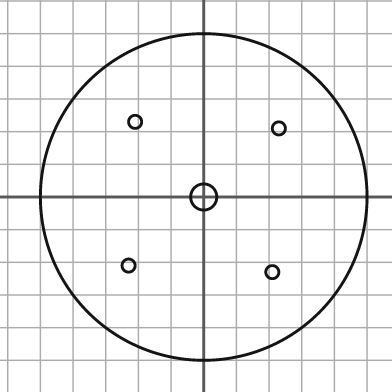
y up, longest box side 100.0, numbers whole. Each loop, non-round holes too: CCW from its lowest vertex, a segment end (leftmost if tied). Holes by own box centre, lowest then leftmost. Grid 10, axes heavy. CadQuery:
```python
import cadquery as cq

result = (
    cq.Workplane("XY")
    .moveTo(0.0, 0.0)
    .circle(50.0)
    .moveTo(21.0, -23.0)
    .circle(2.0)
    .moveTo(-23.0, -21.0)
    .circle(2.0)
    .moveTo(0.0, 0.0)
    .circle(4.0)
    .moveTo(23.0, 21.0)
    .circle(2.0)
    .moveTo(-21.0, 23.0)
    .circle(2.0)
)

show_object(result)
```